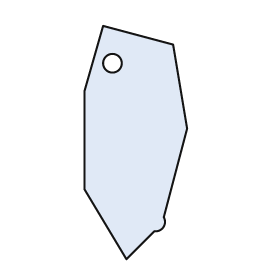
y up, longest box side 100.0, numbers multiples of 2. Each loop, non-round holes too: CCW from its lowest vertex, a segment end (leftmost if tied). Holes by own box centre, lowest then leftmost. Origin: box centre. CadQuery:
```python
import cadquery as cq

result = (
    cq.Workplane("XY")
    .moveTo(-4.0, -50.0)
    .lineTo(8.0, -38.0)
    .threePointArc((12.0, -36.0), (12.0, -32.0))
    .lineTo(22.0, 6.0)
    .lineTo(16.0, 42.0)
    .lineTo(-14.0, 50.0)
    .lineTo(-22.0, 22.0)
    .lineTo(-22.0, -20.0)
    .close()
    .moveTo(-10.0, 34.0)
    .circle(4.0)
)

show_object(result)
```